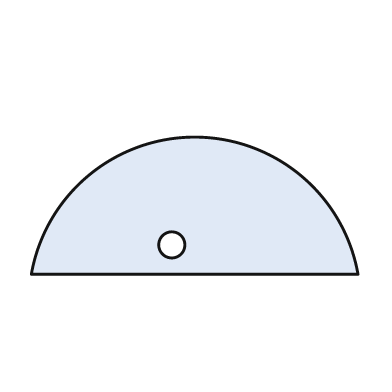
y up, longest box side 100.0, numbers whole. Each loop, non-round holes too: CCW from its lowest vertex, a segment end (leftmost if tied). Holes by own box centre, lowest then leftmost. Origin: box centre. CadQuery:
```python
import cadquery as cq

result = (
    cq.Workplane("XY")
    .moveTo(-50.0, -21.0)
    .lineTo(50.0, -21.0)
    .threePointArc((0.0, 21.0), (-50.0, -21.0))
    .close()
    .moveTo(-7.0, -12.0)
    .circle(4.0)
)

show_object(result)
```